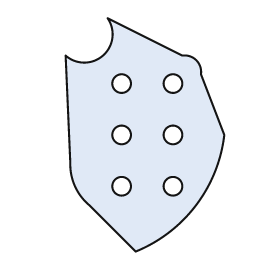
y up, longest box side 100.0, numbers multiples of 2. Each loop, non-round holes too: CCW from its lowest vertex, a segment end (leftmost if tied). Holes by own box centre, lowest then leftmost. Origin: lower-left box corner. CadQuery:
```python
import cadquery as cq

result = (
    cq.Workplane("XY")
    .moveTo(30.0, 0.0)
    .threePointArc((56.0, 20.0), (68.0, 50.0))
    .lineTo(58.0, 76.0)
    .threePointArc((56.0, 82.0), (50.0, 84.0))
    .lineTo(18.0, 100.0)
    .threePointArc((16.0, 84.0), (0.0, 84.0))
    .lineTo(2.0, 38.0)
    .threePointArc((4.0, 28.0), (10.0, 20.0))
    .close()
    .moveTo(24.0, 28.0)
    .circle(4.0)
    .moveTo(46.0, 28.0)
    .circle(4.0)
    .moveTo(24.0, 50.0)
    .circle(4.0)
    .moveTo(46.0, 50.0)
    .circle(4.0)
    .moveTo(24.0, 72.0)
    .circle(4.0)
    .moveTo(46.0, 72.0)
    .circle(4.0)
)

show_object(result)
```